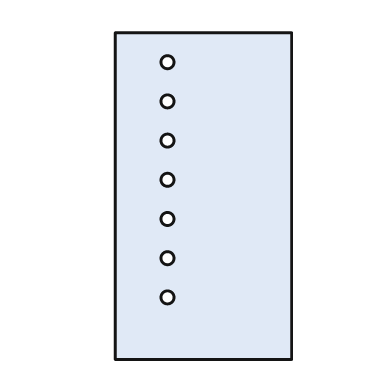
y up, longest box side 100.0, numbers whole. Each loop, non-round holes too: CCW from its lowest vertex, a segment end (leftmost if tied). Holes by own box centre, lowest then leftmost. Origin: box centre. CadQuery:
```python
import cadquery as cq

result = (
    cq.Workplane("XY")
    .moveTo(-27.0, -50.0)
    .lineTo(27.0, -50.0)
    .lineTo(27.0, 50.0)
    .lineTo(-27.0, 50.0)
    .close()
    .moveTo(-11.0, -31.0)
    .circle(2.0)
    .moveTo(-11.0, -19.0)
    .circle(2.0)
    .moveTo(-11.0, -7.0)
    .circle(2.0)
    .moveTo(-11.0, 5.0)
    .circle(2.0)
    .moveTo(-11.0, 17.0)
    .circle(2.0)
    .moveTo(-11.0, 29.0)
    .circle(2.0)
    .moveTo(-11.0, 41.0)
    .circle(2.0)
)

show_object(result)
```